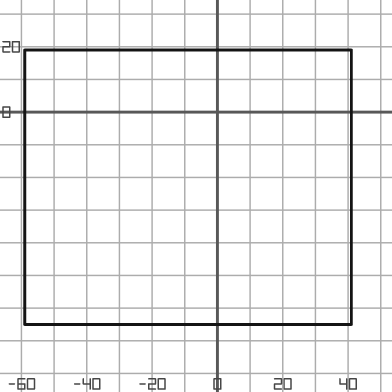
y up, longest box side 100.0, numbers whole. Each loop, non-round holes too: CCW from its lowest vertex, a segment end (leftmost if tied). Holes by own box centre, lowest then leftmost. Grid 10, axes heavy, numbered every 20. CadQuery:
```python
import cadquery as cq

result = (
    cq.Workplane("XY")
    .moveTo(-59.0, -65.0)
    .lineTo(41.0, -65.0)
    .lineTo(41.0, 19.0)
    .lineTo(-59.0, 19.0)
    .close()
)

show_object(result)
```